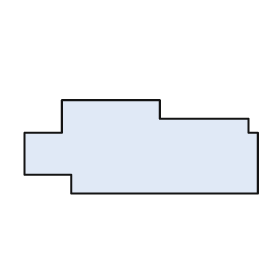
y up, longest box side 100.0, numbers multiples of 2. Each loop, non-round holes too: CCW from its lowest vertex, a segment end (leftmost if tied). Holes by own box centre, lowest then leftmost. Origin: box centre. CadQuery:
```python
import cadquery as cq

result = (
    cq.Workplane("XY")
    .moveTo(-30.0, -20.0)
    .lineTo(50.0, -20.0)
    .lineTo(50.0, 6.0)
    .lineTo(46.0, 6.0)
    .lineTo(46.0, 12.0)
    .lineTo(8.0, 12.0)
    .lineTo(8.0, 20.0)
    .lineTo(-34.0, 20.0)
    .lineTo(-34.0, 6.0)
    .lineTo(-50.0, 6.0)
    .lineTo(-50.0, -12.0)
    .lineTo(-30.0, -12.0)
    .close()
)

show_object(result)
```